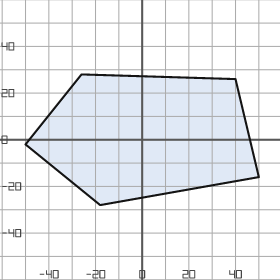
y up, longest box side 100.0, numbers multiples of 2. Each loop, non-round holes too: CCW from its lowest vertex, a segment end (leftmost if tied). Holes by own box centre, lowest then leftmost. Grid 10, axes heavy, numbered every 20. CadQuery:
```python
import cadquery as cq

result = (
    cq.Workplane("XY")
    .moveTo(-18.0, -28.0)
    .lineTo(50.0, -16.0)
    .lineTo(40.0, 26.0)
    .lineTo(-26.0, 28.0)
    .lineTo(-50.0, -2.0)
    .close()
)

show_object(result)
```